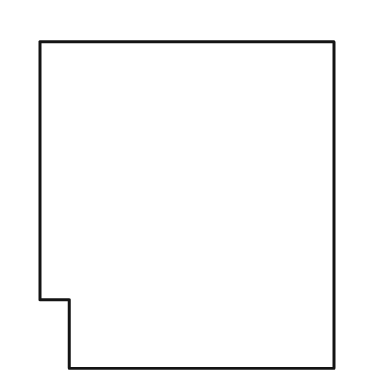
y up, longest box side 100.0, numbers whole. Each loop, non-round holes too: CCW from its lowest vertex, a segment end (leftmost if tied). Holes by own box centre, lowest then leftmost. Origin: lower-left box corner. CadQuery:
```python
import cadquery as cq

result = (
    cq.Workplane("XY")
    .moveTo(9.0, 0.0)
    .lineTo(90.0, 0.0)
    .lineTo(90.0, 100.0)
    .lineTo(0.0, 100.0)
    .lineTo(0.0, 21.0)
    .lineTo(9.0, 21.0)
    .close()
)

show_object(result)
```